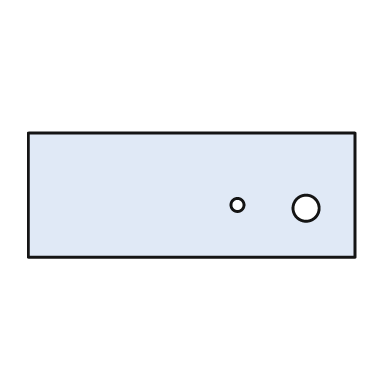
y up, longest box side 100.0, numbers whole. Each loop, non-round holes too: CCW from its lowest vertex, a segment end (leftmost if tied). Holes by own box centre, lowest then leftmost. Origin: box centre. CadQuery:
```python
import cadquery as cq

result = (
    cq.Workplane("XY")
    .moveTo(-50.0, -19.0)
    .lineTo(50.0, -19.0)
    .lineTo(50.0, 19.0)
    .lineTo(-50.0, 19.0)
    .close()
    .moveTo(35.0, -4.0)
    .circle(4.0)
    .moveTo(14.0, -3.0)
    .circle(2.0)
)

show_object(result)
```